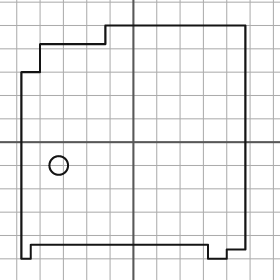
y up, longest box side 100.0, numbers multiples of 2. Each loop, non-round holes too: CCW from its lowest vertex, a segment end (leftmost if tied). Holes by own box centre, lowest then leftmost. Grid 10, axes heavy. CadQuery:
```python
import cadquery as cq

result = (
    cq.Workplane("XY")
    .moveTo(-48.0, -50.0)
    .lineTo(-44.0, -50.0)
    .lineTo(-44.0, -44.0)
    .lineTo(32.0, -44.0)
    .lineTo(32.0, -50.0)
    .lineTo(40.0, -50.0)
    .lineTo(40.0, -46.0)
    .lineTo(48.0, -46.0)
    .lineTo(48.0, 50.0)
    .lineTo(-12.0, 50.0)
    .lineTo(-12.0, 42.0)
    .lineTo(-40.0, 42.0)
    .lineTo(-40.0, 30.0)
    .lineTo(-48.0, 30.0)
    .close()
    .moveTo(-32.0, -10.0)
    .circle(4.0)
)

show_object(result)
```